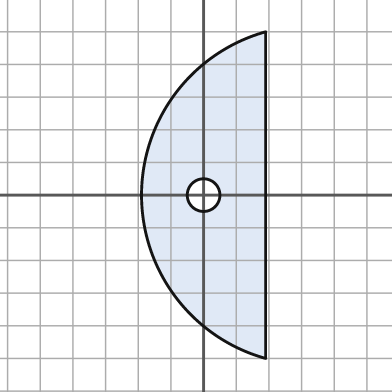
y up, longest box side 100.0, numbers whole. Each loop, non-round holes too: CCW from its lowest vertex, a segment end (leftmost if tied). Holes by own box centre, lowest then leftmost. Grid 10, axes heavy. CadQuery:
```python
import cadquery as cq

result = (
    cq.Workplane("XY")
    .moveTo(19.0, -50.0)
    .lineTo(19.0, 50.0)
    .threePointArc((-19.0, 0.0), (19.0, -50.0))
    .close()
    .moveTo(0.0, 0.0)
    .circle(5.0)
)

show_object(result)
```